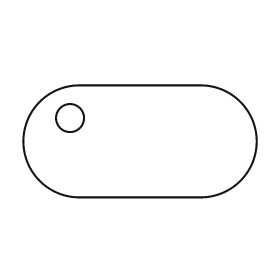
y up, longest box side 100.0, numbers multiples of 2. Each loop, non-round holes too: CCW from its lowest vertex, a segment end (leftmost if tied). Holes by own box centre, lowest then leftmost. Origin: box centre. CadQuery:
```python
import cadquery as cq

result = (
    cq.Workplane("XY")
    .moveTo(-26.0, -24.0)
    .lineTo(26.0, -24.0)
    .threePointArc((50.0, 0.0), (26.0, 24.0))
    .lineTo(-26.0, 24.0)
    .threePointArc((-50.0, 0.0), (-26.0, -24.0))
    .close()
    .moveTo(-30.0, 10.0)
    .circle(6.0)
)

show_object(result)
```